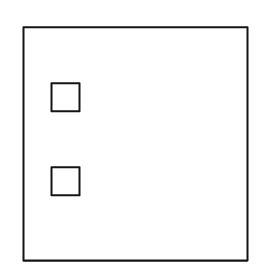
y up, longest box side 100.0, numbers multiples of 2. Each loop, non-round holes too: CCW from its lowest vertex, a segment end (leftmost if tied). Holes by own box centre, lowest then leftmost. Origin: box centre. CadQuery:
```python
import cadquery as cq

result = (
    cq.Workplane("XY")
    .moveTo(-48.0, -50.0)
    .lineTo(48.0, -50.0)
    .lineTo(48.0, 50.0)
    .lineTo(-48.0, 50.0)
    .close()
    .moveTo(-36.0, -22.0)
    .lineTo(-24.0, -22.0)
    .lineTo(-24.0, -10.0)
    .lineTo(-36.0, -10.0)
    .close()
    .moveTo(-36.0, 14.0)
    .lineTo(-24.0, 14.0)
    .lineTo(-24.0, 26.0)
    .lineTo(-36.0, 26.0)
    .close()
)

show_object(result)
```